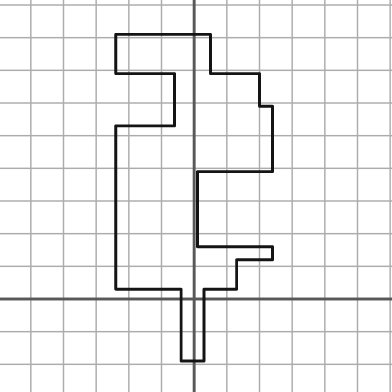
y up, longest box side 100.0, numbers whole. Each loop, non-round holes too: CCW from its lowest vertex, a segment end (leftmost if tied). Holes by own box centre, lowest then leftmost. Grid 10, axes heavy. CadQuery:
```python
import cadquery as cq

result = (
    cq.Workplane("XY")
    .moveTo(-4.0, -19.0)
    .lineTo(3.0, -19.0)
    .lineTo(3.0, 3.0)
    .lineTo(13.0, 3.0)
    .lineTo(13.0, 12.0)
    .lineTo(24.0, 12.0)
    .lineTo(24.0, 16.0)
    .lineTo(1.0, 16.0)
    .lineTo(1.0, 39.0)
    .lineTo(24.0, 39.0)
    .lineTo(24.0, 59.0)
    .lineTo(20.0, 59.0)
    .lineTo(20.0, 69.0)
    .lineTo(5.0, 69.0)
    .lineTo(5.0, 81.0)
    .lineTo(-24.0, 81.0)
    .lineTo(-24.0, 69.0)
    .lineTo(-6.0, 69.0)
    .lineTo(-6.0, 53.0)
    .lineTo(-24.0, 53.0)
    .lineTo(-24.0, 3.0)
    .lineTo(-4.0, 3.0)
    .close()
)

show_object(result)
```